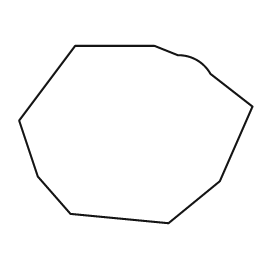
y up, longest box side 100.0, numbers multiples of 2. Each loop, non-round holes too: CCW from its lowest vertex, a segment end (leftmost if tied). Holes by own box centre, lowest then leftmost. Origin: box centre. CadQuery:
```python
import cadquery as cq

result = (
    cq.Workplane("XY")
    .moveTo(14.0, -38.0)
    .lineTo(36.0, -20.0)
    .lineTo(50.0, 12.0)
    .lineTo(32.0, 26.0)
    .threePointArc((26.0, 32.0), (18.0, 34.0))
    .lineTo(8.0, 38.0)
    .lineTo(-26.0, 38.0)
    .lineTo(-50.0, 6.0)
    .lineTo(-42.0, -18.0)
    .lineTo(-28.0, -34.0)
    .close()
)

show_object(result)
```